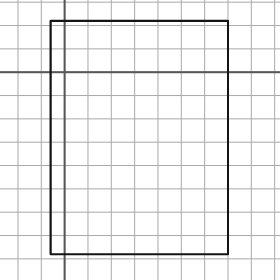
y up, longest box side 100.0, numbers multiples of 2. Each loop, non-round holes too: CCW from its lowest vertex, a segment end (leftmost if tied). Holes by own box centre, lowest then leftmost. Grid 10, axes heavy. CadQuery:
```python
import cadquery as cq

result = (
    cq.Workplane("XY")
    .moveTo(-6.0, -78.0)
    .lineTo(70.0, -78.0)
    .lineTo(70.0, 22.0)
    .lineTo(-6.0, 22.0)
    .close()
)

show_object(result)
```